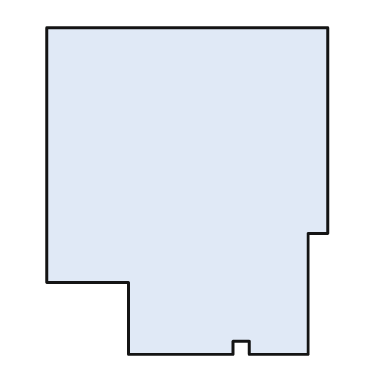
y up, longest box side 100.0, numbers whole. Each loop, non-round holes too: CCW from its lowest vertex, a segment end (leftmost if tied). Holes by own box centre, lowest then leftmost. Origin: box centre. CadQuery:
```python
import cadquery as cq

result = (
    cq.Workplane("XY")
    .moveTo(-18.0, -50.0)
    .lineTo(14.0, -50.0)
    .lineTo(14.0, -46.0)
    .lineTo(19.0, -46.0)
    .lineTo(19.0, -50.0)
    .lineTo(37.0, -50.0)
    .lineTo(37.0, -13.0)
    .lineTo(43.0, -13.0)
    .lineTo(43.0, 50.0)
    .lineTo(-43.0, 50.0)
    .lineTo(-43.0, -28.0)
    .lineTo(-18.0, -28.0)
    .close()
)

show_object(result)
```